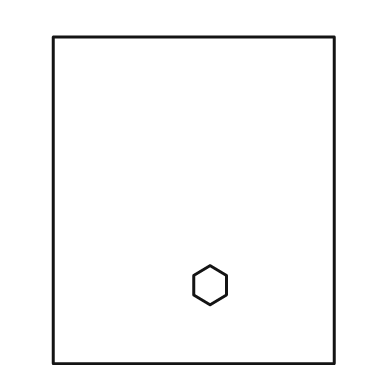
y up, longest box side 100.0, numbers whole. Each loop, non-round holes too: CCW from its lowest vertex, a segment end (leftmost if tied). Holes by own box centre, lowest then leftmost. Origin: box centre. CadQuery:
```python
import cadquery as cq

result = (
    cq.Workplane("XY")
    .moveTo(-43.0, -50.0)
    .lineTo(43.0, -50.0)
    .lineTo(43.0, 50.0)
    .lineTo(-43.0, 50.0)
    .close()
    .moveTo(5.0, -32.0)
    .lineTo(10.0, -29.0)
    .lineTo(10.0, -23.0)
    .lineTo(5.0, -20.0)
    .lineTo(0.0, -23.0)
    .lineTo(0.0, -29.0)
    .close()
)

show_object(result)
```